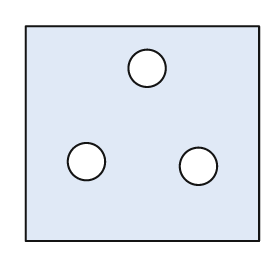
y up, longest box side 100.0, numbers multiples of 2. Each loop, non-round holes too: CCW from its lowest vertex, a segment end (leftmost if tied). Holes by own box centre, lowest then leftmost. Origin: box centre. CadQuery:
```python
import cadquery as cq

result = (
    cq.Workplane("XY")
    .moveTo(-50.0, -46.0)
    .lineTo(50.0, -46.0)
    .lineTo(50.0, 46.0)
    .lineTo(-50.0, 46.0)
    .close()
    .moveTo(24.0, -14.0)
    .circle(8.0)
    .moveTo(-24.0, -12.0)
    .circle(8.0)
    .moveTo(2.0, 28.0)
    .circle(8.0)
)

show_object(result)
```